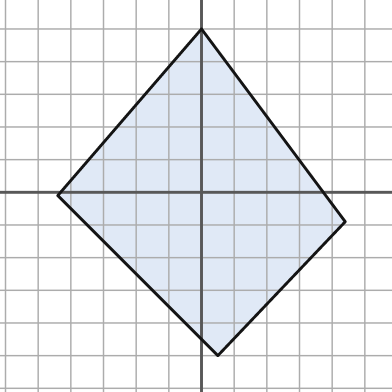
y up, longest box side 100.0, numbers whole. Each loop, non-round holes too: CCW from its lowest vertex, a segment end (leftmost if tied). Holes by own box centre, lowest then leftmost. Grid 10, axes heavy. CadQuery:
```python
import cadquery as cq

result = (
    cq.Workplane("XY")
    .moveTo(5.0, -50.0)
    .lineTo(44.0, -9.0)
    .lineTo(0.0, 50.0)
    .lineTo(-44.0, -1.0)
    .close()
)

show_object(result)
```